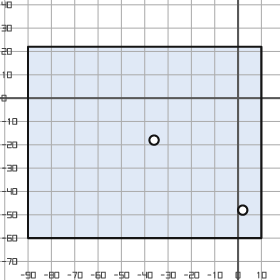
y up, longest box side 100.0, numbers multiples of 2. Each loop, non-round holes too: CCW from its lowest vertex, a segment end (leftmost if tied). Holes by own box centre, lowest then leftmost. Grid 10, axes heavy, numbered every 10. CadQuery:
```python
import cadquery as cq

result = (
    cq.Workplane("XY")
    .moveTo(-90.0, -60.0)
    .lineTo(10.0, -60.0)
    .lineTo(10.0, 22.0)
    .lineTo(-90.0, 22.0)
    .close()
    .moveTo(2.0, -48.0)
    .circle(2.0)
    .moveTo(-36.0, -18.0)
    .circle(2.0)
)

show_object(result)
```